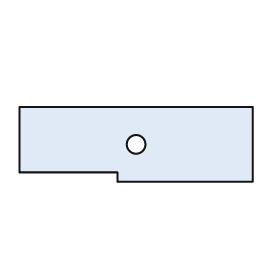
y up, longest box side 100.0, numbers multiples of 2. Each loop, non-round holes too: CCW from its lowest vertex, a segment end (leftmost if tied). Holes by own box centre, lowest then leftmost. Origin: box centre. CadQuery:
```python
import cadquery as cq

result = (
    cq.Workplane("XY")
    .moveTo(-8.0, -16.0)
    .lineTo(50.0, -16.0)
    .lineTo(50.0, 16.0)
    .lineTo(-50.0, 16.0)
    .lineTo(-50.0, -12.0)
    .lineTo(-8.0, -12.0)
    .close()
    .moveTo(0.0, 0.0)
    .circle(4.0)
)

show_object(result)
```